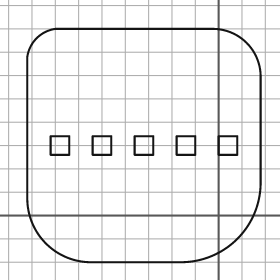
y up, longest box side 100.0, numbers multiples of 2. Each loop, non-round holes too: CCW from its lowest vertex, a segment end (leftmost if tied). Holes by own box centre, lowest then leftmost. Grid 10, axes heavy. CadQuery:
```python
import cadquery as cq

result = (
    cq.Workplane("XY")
    .moveTo(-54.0, -20.0)
    .lineTo(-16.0, -20.0)
    .threePointArc((8.0, -10.0), (18.0, 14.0))
    .lineTo(18.0, 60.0)
    .threePointArc((12.0, 74.0), (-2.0, 80.0))
    .lineTo(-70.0, 80.0)
    .threePointArc((-78.0, 76.0), (-82.0, 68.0))
    .lineTo(-82.0, 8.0)
    .threePointArc((-74.0, -12.0), (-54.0, -20.0))
    .close()
    .moveTo(-72.0, 26.0)
    .lineTo(-64.0, 26.0)
    .lineTo(-64.0, 34.0)
    .lineTo(-72.0, 34.0)
    .close()
    .moveTo(-54.0, 26.0)
    .lineTo(-46.0, 26.0)
    .lineTo(-46.0, 34.0)
    .lineTo(-54.0, 34.0)
    .close()
    .moveTo(-36.0, 26.0)
    .lineTo(-28.0, 26.0)
    .lineTo(-28.0, 34.0)
    .lineTo(-36.0, 34.0)
    .close()
    .moveTo(-18.0, 26.0)
    .lineTo(-10.0, 26.0)
    .lineTo(-10.0, 34.0)
    .lineTo(-18.0, 34.0)
    .close()
    .moveTo(0.0, 26.0)
    .lineTo(8.0, 26.0)
    .lineTo(8.0, 34.0)
    .lineTo(0.0, 34.0)
    .close()
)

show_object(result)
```